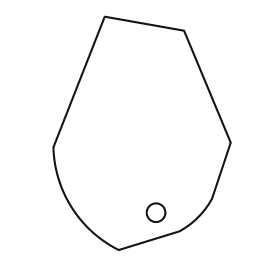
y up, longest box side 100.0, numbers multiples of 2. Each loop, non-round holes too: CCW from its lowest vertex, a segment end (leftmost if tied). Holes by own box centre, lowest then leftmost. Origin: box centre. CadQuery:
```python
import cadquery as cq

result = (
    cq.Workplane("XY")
    .moveTo(-10.0, -50.0)
    .lineTo(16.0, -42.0)
    .threePointArc((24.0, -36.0), (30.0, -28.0))
    .lineTo(38.0, -4.0)
    .lineTo(18.0, 44.0)
    .lineTo(-16.0, 50.0)
    .lineTo(-38.0, -6.0)
    .threePointArc((-30.0, -32.0), (-10.0, -50.0))
    .close()
    .moveTo(6.0, -34.0)
    .circle(4.0)
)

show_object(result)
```